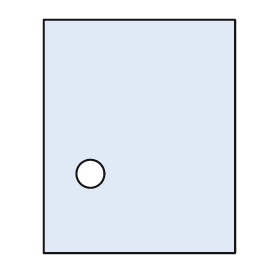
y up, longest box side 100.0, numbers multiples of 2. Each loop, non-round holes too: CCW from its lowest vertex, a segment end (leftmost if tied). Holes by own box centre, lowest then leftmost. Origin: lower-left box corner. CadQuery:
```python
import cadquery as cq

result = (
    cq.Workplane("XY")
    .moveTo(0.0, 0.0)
    .lineTo(82.0, 0.0)
    .lineTo(82.0, 100.0)
    .lineTo(0.0, 100.0)
    .close()
    .moveTo(20.0, 34.0)
    .circle(6.0)
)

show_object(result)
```